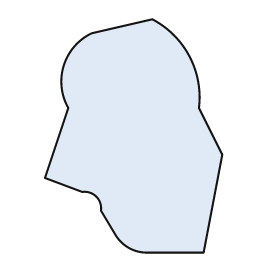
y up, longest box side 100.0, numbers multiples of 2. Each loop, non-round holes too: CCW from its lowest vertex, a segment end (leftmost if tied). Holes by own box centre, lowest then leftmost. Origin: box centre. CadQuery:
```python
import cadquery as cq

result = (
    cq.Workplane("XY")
    .moveTo(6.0, -50.0)
    .lineTo(30.0, -50.0)
    .lineTo(38.0, -8.0)
    .lineTo(28.0, 12.0)
    .threePointArc((24.0, 34.0), (8.0, 50.0))
    .lineTo(-18.0, 44.0)
    .threePointArc((-30.0, 30.0), (-28.0, 12.0))
    .lineTo(-38.0, -18.0)
    .lineTo(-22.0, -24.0)
    .threePointArc((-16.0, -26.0), (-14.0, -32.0))
    .lineTo(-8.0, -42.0)
    .threePointArc((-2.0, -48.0), (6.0, -50.0))
    .close()
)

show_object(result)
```